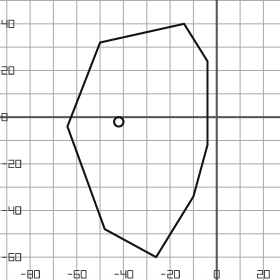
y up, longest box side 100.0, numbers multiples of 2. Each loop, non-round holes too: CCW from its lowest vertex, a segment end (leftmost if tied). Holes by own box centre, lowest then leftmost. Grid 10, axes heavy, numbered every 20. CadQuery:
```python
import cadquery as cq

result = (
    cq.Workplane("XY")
    .moveTo(-26.0, -60.0)
    .lineTo(-10.0, -34.0)
    .lineTo(-4.0, -12.0)
    .lineTo(-4.0, 24.0)
    .lineTo(-14.0, 40.0)
    .lineTo(-50.0, 32.0)
    .lineTo(-64.0, -4.0)
    .lineTo(-48.0, -48.0)
    .close()
    .moveTo(-42.0, -2.0)
    .circle(2.0)
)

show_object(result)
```